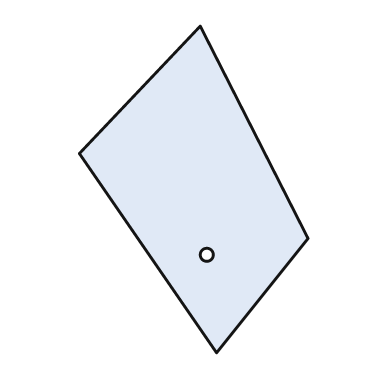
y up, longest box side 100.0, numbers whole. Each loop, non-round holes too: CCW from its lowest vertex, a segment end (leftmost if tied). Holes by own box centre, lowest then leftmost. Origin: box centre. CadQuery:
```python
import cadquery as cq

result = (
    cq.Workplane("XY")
    .moveTo(7.0, -50.0)
    .lineTo(35.0, -15.0)
    .lineTo(2.0, 50.0)
    .lineTo(-35.0, 11.0)
    .close()
    .moveTo(4.0, -20.0)
    .circle(2.0)
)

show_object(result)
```